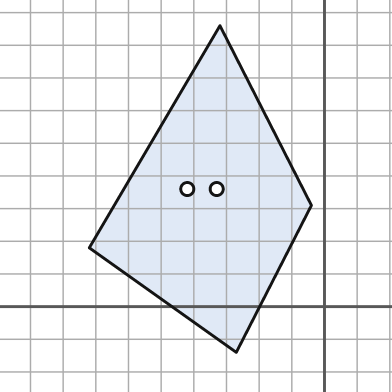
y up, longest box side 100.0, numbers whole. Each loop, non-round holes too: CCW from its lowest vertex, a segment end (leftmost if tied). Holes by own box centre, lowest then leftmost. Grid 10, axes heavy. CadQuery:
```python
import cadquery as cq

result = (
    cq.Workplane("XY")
    .moveTo(-27.0, -14.0)
    .lineTo(-4.0, 31.0)
    .lineTo(-32.0, 86.0)
    .lineTo(-72.0, 18.0)
    .close()
    .moveTo(-42.0, 36.0)
    .circle(2.0)
    .moveTo(-33.0, 36.0)
    .circle(2.0)
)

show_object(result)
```